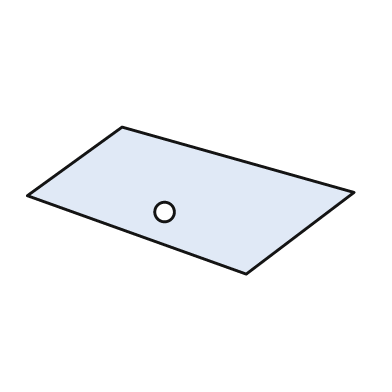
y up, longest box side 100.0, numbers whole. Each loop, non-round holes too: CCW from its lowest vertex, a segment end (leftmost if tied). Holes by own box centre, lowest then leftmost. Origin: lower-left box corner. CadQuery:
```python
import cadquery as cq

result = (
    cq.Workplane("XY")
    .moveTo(67.0, 0.0)
    .lineTo(100.0, 25.0)
    .lineTo(29.0, 45.0)
    .lineTo(0.0, 24.0)
    .close()
    .moveTo(42.0, 19.0)
    .circle(3.0)
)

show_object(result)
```